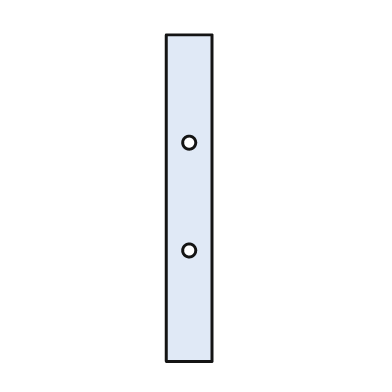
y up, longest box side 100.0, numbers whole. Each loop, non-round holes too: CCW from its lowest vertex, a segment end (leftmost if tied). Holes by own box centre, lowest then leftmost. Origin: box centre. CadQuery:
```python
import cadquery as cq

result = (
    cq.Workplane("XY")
    .moveTo(-7.0, -50.0)
    .lineTo(7.0, -50.0)
    .lineTo(7.0, 50.0)
    .lineTo(-7.0, 50.0)
    .close()
    .moveTo(0.0, -16.0)
    .circle(2.0)
    .moveTo(0.0, 17.0)
    .circle(2.0)
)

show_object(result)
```